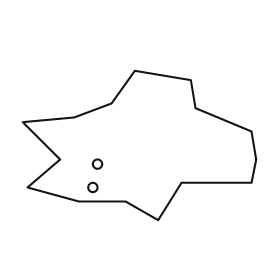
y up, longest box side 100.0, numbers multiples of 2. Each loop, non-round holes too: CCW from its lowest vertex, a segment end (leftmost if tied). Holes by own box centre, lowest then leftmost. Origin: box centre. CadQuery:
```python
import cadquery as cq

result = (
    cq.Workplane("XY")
    .moveTo(8.0, -32.0)
    .lineTo(18.0, -16.0)
    .lineTo(48.0, -16.0)
    .lineTo(50.0, -6.0)
    .lineTo(48.0, 6.0)
    .lineTo(24.0, 16.0)
    .lineTo(22.0, 28.0)
    .lineTo(-2.0, 32.0)
    .lineTo(-12.0, 18.0)
    .lineTo(-28.0, 12.0)
    .lineTo(-50.0, 10.0)
    .lineTo(-34.0, -6.0)
    .lineTo(-48.0, -18.0)
    .lineTo(-26.0, -24.0)
    .lineTo(-6.0, -24.0)
    .close()
    .moveTo(-20.0, -18.0)
    .circle(2.0)
    .moveTo(-18.0, -8.0)
    .circle(2.0)
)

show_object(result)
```